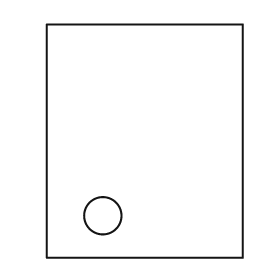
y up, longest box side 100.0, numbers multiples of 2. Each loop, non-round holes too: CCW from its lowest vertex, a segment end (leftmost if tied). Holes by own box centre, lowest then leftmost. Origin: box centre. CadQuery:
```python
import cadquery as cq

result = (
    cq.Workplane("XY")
    .moveTo(-42.0, -50.0)
    .lineTo(42.0, -50.0)
    .lineTo(42.0, 50.0)
    .lineTo(-42.0, 50.0)
    .close()
    .moveTo(-18.0, -32.0)
    .circle(8.0)
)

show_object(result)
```